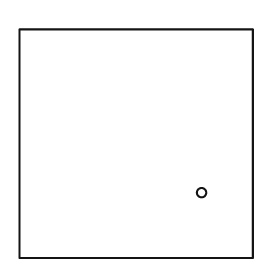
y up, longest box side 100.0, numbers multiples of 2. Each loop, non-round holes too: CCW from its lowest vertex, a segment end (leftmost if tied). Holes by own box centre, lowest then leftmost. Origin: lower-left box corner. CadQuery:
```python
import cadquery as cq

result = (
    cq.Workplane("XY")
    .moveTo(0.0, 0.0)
    .lineTo(100.0, 0.0)
    .lineTo(100.0, 98.0)
    .lineTo(0.0, 98.0)
    .close()
    .moveTo(78.0, 28.0)
    .circle(2.0)
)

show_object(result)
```